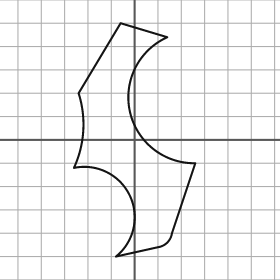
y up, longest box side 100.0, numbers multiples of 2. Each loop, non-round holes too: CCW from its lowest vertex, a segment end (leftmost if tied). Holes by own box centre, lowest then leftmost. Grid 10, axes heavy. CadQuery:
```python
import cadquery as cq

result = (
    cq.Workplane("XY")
    .moveTo(-8.0, -50.0)
    .lineTo(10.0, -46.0)
    .threePointArc((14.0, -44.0), (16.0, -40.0))
    .lineTo(26.0, -10.0)
    .threePointArc((-2.0, 12.0), (14.0, 44.0))
    .lineTo(-6.0, 50.0)
    .lineTo(-24.0, 20.0)
    .threePointArc((-22.0, 4.0), (-26.0, -12.0))
    .threePointArc((-2.0, -24.0), (-8.0, -50.0))
    .close()
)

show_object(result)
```